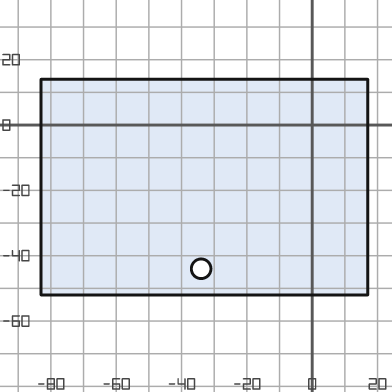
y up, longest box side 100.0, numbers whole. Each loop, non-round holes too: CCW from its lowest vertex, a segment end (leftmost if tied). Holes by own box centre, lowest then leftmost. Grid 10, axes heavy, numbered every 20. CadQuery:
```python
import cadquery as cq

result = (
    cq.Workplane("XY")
    .moveTo(-83.0, -52.0)
    .lineTo(17.0, -52.0)
    .lineTo(17.0, 14.0)
    .lineTo(-83.0, 14.0)
    .close()
    .moveTo(-34.0, -44.0)
    .circle(3.0)
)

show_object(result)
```